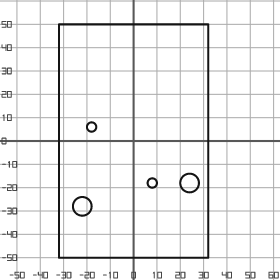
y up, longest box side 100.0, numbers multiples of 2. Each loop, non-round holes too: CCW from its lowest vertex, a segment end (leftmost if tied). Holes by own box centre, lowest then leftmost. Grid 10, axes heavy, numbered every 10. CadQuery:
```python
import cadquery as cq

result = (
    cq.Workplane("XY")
    .moveTo(-32.0, -50.0)
    .lineTo(32.0, -50.0)
    .lineTo(32.0, 50.0)
    .lineTo(-32.0, 50.0)
    .close()
    .moveTo(-22.0, -28.0)
    .circle(4.0)
    .moveTo(8.0, -18.0)
    .circle(2.0)
    .moveTo(24.0, -18.0)
    .circle(4.0)
    .moveTo(-18.0, 6.0)
    .circle(2.0)
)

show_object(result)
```